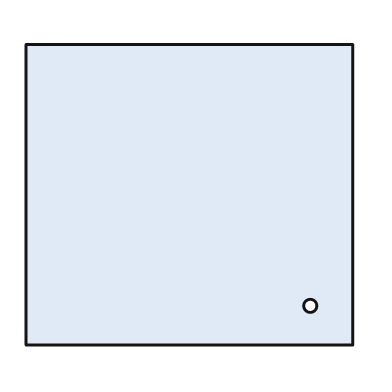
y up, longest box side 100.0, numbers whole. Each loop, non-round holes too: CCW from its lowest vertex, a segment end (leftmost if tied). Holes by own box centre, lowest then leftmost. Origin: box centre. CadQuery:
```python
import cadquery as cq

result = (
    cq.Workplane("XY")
    .moveTo(-50.0, -46.0)
    .lineTo(50.0, -46.0)
    .lineTo(50.0, 46.0)
    .lineTo(-50.0, 46.0)
    .close()
    .moveTo(37.0, -34.0)
    .circle(2.0)
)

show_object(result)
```